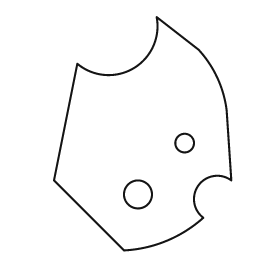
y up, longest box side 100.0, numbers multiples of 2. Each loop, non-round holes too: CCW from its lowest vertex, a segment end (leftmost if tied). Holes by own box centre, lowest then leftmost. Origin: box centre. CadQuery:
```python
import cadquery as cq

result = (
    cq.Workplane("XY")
    .moveTo(-8.0, -50.0)
    .threePointArc((10.0, -46.0), (26.0, -36.0))
    .threePointArc((24.0, -22.0), (38.0, -20.0))
    .lineTo(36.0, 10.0)
    .threePointArc((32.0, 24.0), (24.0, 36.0))
    .lineTo(6.0, 50.0)
    .threePointArc((-4.0, 28.0), (-28.0, 30.0))
    .lineTo(-38.0, -20.0)
    .close()
    .moveTo(-2.0, -26.0)
    .circle(6.0)
    .moveTo(18.0, -4.0)
    .circle(4.0)
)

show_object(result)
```